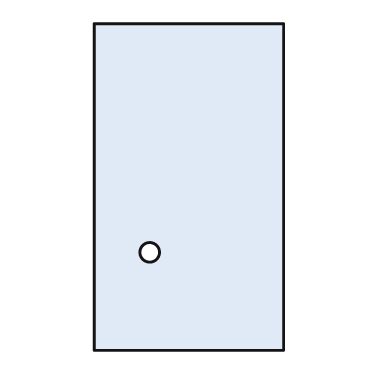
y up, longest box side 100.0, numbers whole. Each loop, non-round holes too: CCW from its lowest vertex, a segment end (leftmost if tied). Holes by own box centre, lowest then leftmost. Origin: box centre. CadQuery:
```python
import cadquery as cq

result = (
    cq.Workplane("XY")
    .moveTo(-29.0, -50.0)
    .lineTo(29.0, -50.0)
    .lineTo(29.0, 50.0)
    .lineTo(-29.0, 50.0)
    .close()
    .moveTo(-12.0, -20.0)
    .circle(3.0)
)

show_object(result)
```